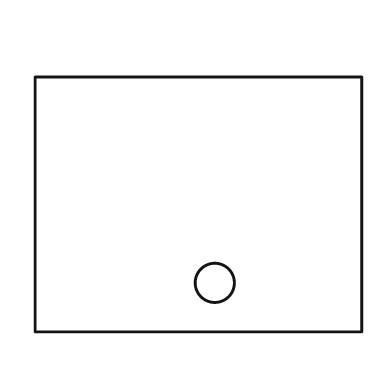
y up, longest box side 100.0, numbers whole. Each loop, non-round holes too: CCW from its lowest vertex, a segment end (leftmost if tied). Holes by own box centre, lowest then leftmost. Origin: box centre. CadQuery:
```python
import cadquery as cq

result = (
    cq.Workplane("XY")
    .moveTo(-50.0, -39.0)
    .lineTo(50.0, -39.0)
    .lineTo(50.0, 39.0)
    .lineTo(-50.0, 39.0)
    .close()
    .moveTo(5.0, -24.0)
    .circle(6.0)
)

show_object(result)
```